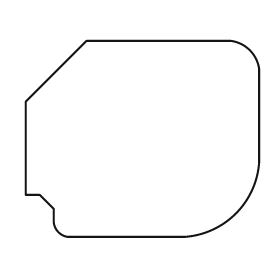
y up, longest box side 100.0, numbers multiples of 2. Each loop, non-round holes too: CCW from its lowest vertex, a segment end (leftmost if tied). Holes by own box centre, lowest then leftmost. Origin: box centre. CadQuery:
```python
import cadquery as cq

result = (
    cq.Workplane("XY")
    .moveTo(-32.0, -42.0)
    .lineTo(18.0, -42.0)
    .threePointArc((40.0, -32.0), (50.0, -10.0))
    .lineTo(50.0, 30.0)
    .threePointArc((46.0, 38.0), (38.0, 42.0))
    .lineTo(-24.0, 42.0)
    .lineTo(-50.0, 16.0)
    .lineTo(-50.0, -24.0)
    .lineTo(-44.0, -24.0)
    .lineTo(-38.0, -30.0)
    .lineTo(-38.0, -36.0)
    .threePointArc((-36.0, -40.0), (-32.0, -42.0))
    .close()
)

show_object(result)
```